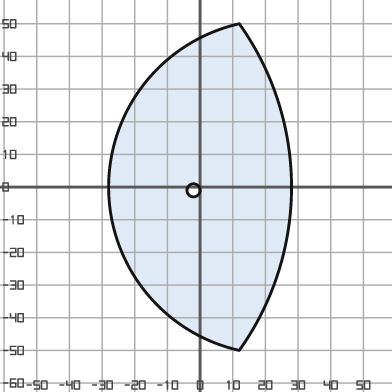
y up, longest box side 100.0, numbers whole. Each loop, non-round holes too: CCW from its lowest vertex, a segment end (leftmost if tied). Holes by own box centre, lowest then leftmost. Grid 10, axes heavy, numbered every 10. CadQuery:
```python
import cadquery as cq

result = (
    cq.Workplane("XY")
    .moveTo(12.0, -50.0)
    .threePointArc((28.0, 0.0), (12.0, 50.0))
    .threePointArc((-28.0, 0.0), (12.0, -50.0))
    .close()
    .moveTo(-2.0, -1.0)
    .circle(2.0)
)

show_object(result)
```